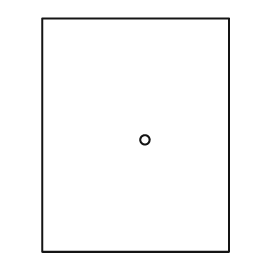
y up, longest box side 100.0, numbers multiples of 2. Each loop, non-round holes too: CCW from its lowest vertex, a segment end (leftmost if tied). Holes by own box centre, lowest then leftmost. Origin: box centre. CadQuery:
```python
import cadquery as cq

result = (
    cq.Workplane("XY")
    .moveTo(-40.0, -50.0)
    .lineTo(40.0, -50.0)
    .lineTo(40.0, 50.0)
    .lineTo(-40.0, 50.0)
    .close()
    .moveTo(4.0, -2.0)
    .circle(2.0)
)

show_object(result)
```